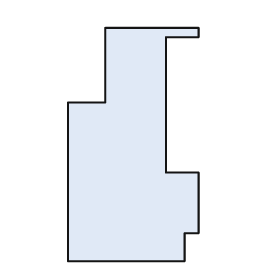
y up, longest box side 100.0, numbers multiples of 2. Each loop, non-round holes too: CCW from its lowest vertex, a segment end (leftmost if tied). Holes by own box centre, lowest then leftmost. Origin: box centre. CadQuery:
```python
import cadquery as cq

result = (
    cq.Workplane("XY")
    .moveTo(-28.0, -50.0)
    .lineTo(22.0, -50.0)
    .lineTo(22.0, -38.0)
    .lineTo(28.0, -38.0)
    .lineTo(28.0, -12.0)
    .lineTo(14.0, -12.0)
    .lineTo(14.0, 46.0)
    .lineTo(28.0, 46.0)
    .lineTo(28.0, 50.0)
    .lineTo(-12.0, 50.0)
    .lineTo(-12.0, 18.0)
    .lineTo(-28.0, 18.0)
    .close()
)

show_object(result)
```